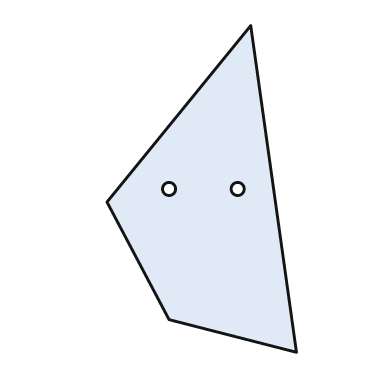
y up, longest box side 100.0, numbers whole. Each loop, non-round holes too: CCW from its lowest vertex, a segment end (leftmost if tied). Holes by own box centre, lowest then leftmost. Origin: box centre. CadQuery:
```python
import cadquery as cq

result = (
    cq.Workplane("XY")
    .moveTo(29.0, -50.0)
    .lineTo(15.0, 50.0)
    .lineTo(-29.0, -4.0)
    .lineTo(-10.0, -40.0)
    .close()
    .moveTo(-10.0, 0.0)
    .circle(2.0)
    .moveTo(11.0, 0.0)
    .circle(2.0)
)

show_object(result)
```